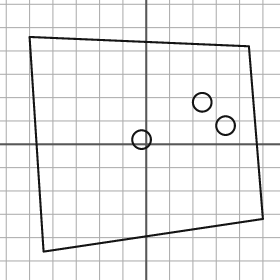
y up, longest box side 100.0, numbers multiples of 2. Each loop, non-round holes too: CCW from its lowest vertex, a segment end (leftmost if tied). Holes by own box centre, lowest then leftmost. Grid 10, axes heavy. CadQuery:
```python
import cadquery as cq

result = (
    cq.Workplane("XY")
    .moveTo(-44.0, -46.0)
    .lineTo(50.0, -32.0)
    .lineTo(44.0, 42.0)
    .lineTo(-50.0, 46.0)
    .close()
    .moveTo(-2.0, 2.0)
    .circle(4.0)
    .moveTo(34.0, 8.0)
    .circle(4.0)
    .moveTo(24.0, 18.0)
    .circle(4.0)
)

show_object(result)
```